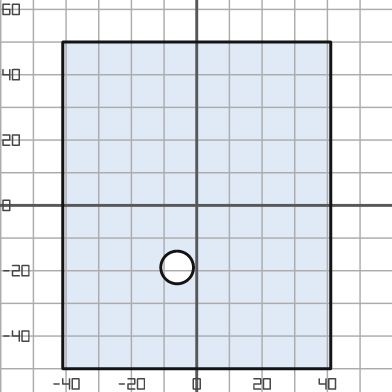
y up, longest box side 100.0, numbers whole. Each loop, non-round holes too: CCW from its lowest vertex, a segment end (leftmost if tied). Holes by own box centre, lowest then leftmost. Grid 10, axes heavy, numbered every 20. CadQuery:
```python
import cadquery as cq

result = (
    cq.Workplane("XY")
    .moveTo(-41.0, -50.0)
    .lineTo(41.0, -50.0)
    .lineTo(41.0, 50.0)
    .lineTo(-41.0, 50.0)
    .close()
    .moveTo(-6.0, -19.0)
    .circle(5.0)
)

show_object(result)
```